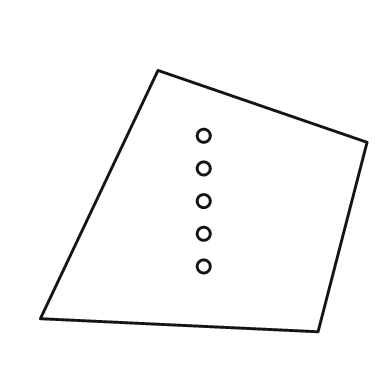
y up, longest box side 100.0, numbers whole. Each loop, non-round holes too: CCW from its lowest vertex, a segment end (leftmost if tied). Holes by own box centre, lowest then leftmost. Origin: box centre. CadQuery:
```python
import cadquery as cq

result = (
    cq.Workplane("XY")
    .moveTo(35.0, -40.0)
    .lineTo(50.0, 18.0)
    .lineTo(-14.0, 40.0)
    .lineTo(-50.0, -36.0)
    .close()
    .moveTo(0.0, -20.0)
    .circle(2.0)
    .moveTo(0.0, -10.0)
    .circle(2.0)
    .moveTo(0.0, 0.0)
    .circle(2.0)
    .moveTo(0.0, 10.0)
    .circle(2.0)
    .moveTo(0.0, 20.0)
    .circle(2.0)
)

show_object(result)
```